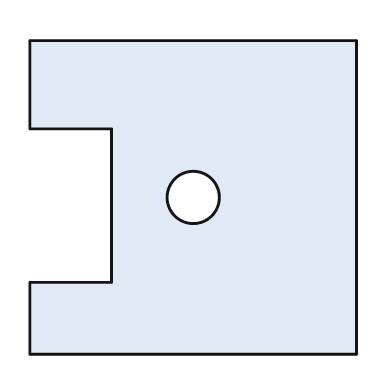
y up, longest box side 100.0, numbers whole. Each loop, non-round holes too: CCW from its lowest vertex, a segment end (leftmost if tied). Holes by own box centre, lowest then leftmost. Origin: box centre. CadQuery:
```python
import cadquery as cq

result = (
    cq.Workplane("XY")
    .moveTo(-50.0, -48.0)
    .lineTo(50.0, -48.0)
    .lineTo(50.0, 48.0)
    .lineTo(-50.0, 48.0)
    .lineTo(-50.0, 21.0)
    .lineTo(-25.0, 21.0)
    .lineTo(-25.0, -26.0)
    .lineTo(-50.0, -26.0)
    .close()
    .moveTo(0.0, 0.0)
    .circle(8.0)
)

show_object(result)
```